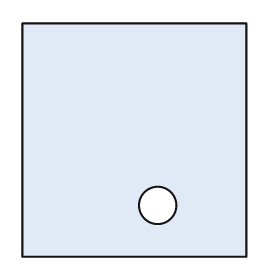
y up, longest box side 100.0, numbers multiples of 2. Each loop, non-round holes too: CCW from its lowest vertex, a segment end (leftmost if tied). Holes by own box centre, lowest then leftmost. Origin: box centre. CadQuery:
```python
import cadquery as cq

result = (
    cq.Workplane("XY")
    .moveTo(-48.0, -50.0)
    .lineTo(48.0, -50.0)
    .lineTo(48.0, 50.0)
    .lineTo(-48.0, 50.0)
    .close()
    .moveTo(10.0, -28.0)
    .circle(8.0)
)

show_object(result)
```